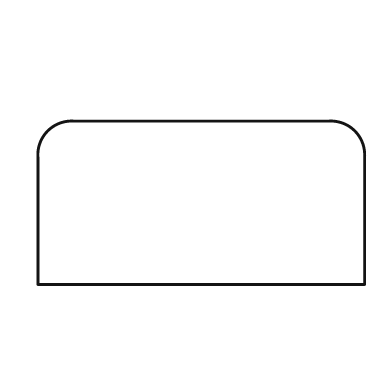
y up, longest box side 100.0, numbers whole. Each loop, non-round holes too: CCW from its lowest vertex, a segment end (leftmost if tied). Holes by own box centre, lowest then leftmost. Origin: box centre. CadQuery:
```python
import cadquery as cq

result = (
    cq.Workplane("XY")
    .moveTo(-50.0, -25.0)
    .lineTo(50.0, -25.0)
    .lineTo(50.0, 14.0)
    .threePointArc((47.0, 22.0), (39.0, 25.0))
    .lineTo(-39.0, 25.0)
    .threePointArc((-47.0, 22.0), (-50.0, 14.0))
    .close()
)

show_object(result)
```